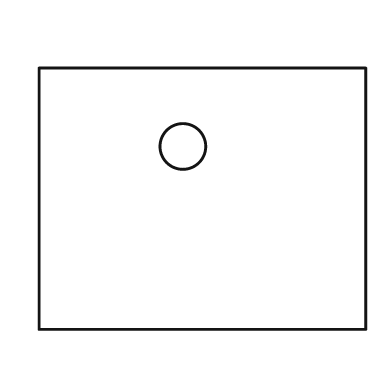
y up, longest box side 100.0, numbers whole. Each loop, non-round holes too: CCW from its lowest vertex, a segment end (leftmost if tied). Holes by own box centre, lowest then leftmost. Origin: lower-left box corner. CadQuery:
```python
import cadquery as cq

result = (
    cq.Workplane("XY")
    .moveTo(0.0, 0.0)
    .lineTo(100.0, 0.0)
    .lineTo(100.0, 80.0)
    .lineTo(0.0, 80.0)
    .close()
    .moveTo(44.0, 56.0)
    .circle(7.0)
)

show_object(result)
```